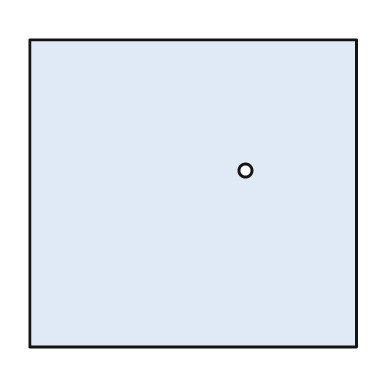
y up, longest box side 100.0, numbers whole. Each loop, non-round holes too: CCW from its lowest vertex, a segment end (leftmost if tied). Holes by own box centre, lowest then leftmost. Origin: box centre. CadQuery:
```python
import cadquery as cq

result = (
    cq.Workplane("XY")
    .moveTo(-50.0, -47.0)
    .lineTo(50.0, -47.0)
    .lineTo(50.0, 47.0)
    .lineTo(-50.0, 47.0)
    .close()
    .moveTo(16.0, 7.0)
    .circle(2.0)
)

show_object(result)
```